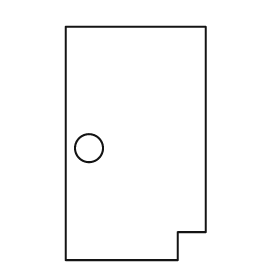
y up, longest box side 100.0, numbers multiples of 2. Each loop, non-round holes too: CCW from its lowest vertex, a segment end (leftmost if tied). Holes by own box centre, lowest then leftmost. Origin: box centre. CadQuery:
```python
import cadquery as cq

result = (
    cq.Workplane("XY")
    .moveTo(-30.0, -50.0)
    .lineTo(18.0, -50.0)
    .lineTo(18.0, -38.0)
    .lineTo(30.0, -38.0)
    .lineTo(30.0, 50.0)
    .lineTo(-30.0, 50.0)
    .close()
    .moveTo(-20.0, -2.0)
    .circle(6.0)
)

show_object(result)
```